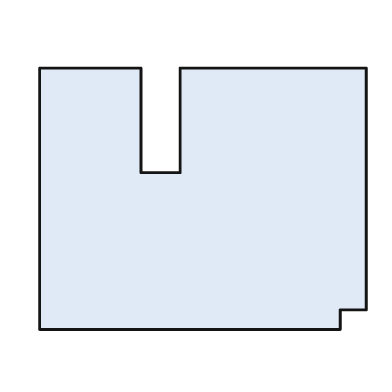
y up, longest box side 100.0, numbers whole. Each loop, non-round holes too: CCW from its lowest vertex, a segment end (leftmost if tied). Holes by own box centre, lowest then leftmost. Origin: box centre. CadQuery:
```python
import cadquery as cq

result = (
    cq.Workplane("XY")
    .moveTo(-50.0, -40.0)
    .lineTo(42.0, -40.0)
    .lineTo(42.0, -34.0)
    .lineTo(50.0, -34.0)
    .lineTo(50.0, 40.0)
    .lineTo(-7.0, 40.0)
    .lineTo(-7.0, 8.0)
    .lineTo(-19.0, 8.0)
    .lineTo(-19.0, 40.0)
    .lineTo(-50.0, 40.0)
    .close()
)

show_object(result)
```